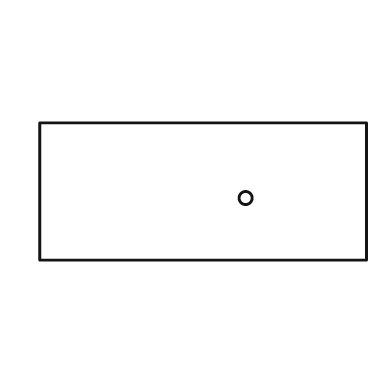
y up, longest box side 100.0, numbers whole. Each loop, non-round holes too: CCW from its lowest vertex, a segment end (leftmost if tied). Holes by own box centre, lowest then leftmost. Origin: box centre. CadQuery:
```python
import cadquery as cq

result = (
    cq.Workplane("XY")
    .moveTo(-50.0, -21.0)
    .lineTo(50.0, -21.0)
    .lineTo(50.0, 21.0)
    .lineTo(-50.0, 21.0)
    .close()
    .moveTo(13.0, -2.0)
    .circle(2.0)
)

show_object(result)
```